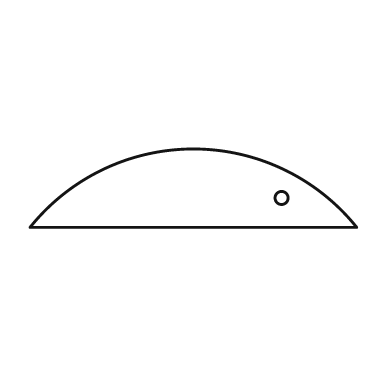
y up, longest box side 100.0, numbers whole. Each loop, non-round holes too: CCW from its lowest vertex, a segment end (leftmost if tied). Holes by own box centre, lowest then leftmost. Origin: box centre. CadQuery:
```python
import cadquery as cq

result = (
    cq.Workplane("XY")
    .moveTo(-50.0, -12.0)
    .lineTo(50.0, -12.0)
    .threePointArc((0.0, 12.0), (-50.0, -12.0))
    .close()
    .moveTo(27.0, -3.0)
    .circle(2.0)
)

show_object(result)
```